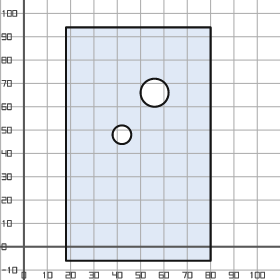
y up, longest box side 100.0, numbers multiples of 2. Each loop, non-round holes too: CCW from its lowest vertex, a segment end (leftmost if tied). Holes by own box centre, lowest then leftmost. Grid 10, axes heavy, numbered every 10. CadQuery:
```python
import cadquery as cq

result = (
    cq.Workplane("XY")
    .moveTo(18.0, -6.0)
    .lineTo(80.0, -6.0)
    .lineTo(80.0, 94.0)
    .lineTo(18.0, 94.0)
    .close()
    .moveTo(42.0, 48.0)
    .circle(4.0)
    .moveTo(56.0, 66.0)
    .circle(6.0)
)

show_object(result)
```